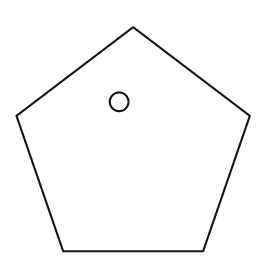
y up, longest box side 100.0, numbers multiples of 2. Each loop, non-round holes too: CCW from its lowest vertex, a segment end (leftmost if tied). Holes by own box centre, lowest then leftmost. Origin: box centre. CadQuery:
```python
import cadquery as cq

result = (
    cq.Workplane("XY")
    .moveTo(-30.0, -48.0)
    .lineTo(30.0, -48.0)
    .lineTo(50.0, 10.0)
    .lineTo(0.0, 48.0)
    .lineTo(-50.0, 10.0)
    .close()
    .moveTo(-6.0, 16.0)
    .circle(4.0)
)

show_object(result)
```